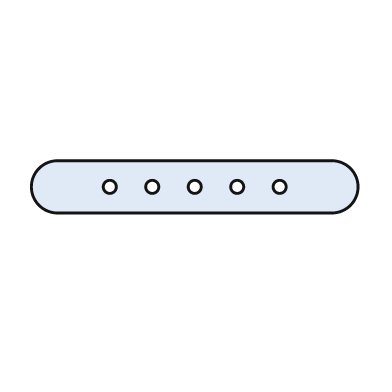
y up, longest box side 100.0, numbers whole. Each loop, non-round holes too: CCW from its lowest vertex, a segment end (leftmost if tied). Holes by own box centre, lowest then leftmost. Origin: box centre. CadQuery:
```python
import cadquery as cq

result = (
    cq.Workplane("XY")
    .moveTo(-42.0, -8.0)
    .lineTo(42.0, -8.0)
    .threePointArc((50.0, 0.0), (42.0, 8.0))
    .lineTo(-42.0, 8.0)
    .threePointArc((-50.0, 0.0), (-42.0, -8.0))
    .close()
    .moveTo(-26.0, 0.0)
    .circle(2.0)
    .moveTo(-13.0, 0.0)
    .circle(2.0)
    .moveTo(0.0, 0.0)
    .circle(2.0)
    .moveTo(13.0, 0.0)
    .circle(2.0)
    .moveTo(26.0, 0.0)
    .circle(2.0)
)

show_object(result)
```